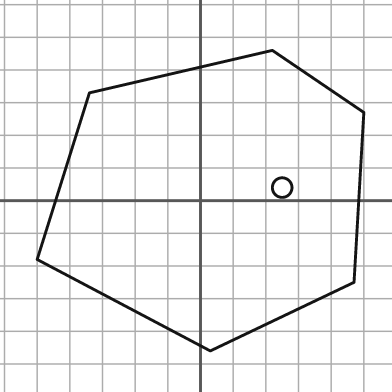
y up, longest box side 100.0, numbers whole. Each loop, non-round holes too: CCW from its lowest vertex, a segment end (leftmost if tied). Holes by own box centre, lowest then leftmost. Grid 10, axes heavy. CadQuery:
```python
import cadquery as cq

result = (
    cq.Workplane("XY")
    .moveTo(3.0, -46.0)
    .lineTo(47.0, -25.0)
    .lineTo(50.0, 27.0)
    .lineTo(22.0, 46.0)
    .lineTo(-34.0, 33.0)
    .lineTo(-50.0, -18.0)
    .close()
    .moveTo(25.0, 4.0)
    .circle(3.0)
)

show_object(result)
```